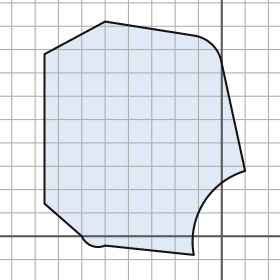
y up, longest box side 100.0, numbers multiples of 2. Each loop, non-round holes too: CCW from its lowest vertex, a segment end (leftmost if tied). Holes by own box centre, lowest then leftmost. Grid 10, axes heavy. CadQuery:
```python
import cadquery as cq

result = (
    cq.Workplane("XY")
    .moveTo(-12.0, -8.0)
    .threePointArc((-8.0, 14.0), (10.0, 28.0))
    .lineTo(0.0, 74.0)
    .threePointArc((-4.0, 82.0), (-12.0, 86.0))
    .lineTo(-50.0, 92.0)
    .lineTo(-76.0, 78.0)
    .lineTo(-76.0, 14.0)
    .lineTo(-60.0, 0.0)
    .threePointArc((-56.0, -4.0), (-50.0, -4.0))
    .close()
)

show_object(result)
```